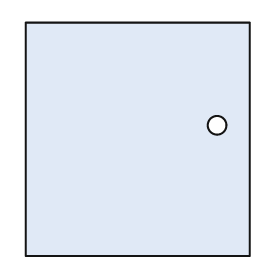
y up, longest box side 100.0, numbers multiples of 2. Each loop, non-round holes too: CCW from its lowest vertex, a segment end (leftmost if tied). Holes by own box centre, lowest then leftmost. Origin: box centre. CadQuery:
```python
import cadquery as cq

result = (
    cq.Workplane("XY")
    .moveTo(-48.0, -50.0)
    .lineTo(48.0, -50.0)
    .lineTo(48.0, 50.0)
    .lineTo(-48.0, 50.0)
    .close()
    .moveTo(34.0, 6.0)
    .circle(4.0)
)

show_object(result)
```